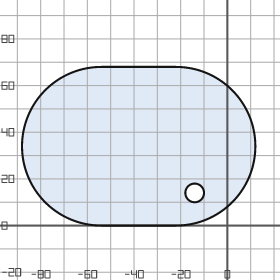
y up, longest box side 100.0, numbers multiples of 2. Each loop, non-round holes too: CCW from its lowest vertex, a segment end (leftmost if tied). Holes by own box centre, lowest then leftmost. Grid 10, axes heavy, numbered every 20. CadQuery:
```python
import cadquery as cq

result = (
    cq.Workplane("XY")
    .moveTo(-54.0, 0.0)
    .lineTo(-22.0, 0.0)
    .threePointArc((12.0, 34.0), (-22.0, 68.0))
    .lineTo(-54.0, 68.0)
    .threePointArc((-88.0, 34.0), (-54.0, 0.0))
    .close()
    .moveTo(-14.0, 14.0)
    .circle(4.0)
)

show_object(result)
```